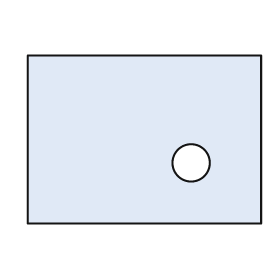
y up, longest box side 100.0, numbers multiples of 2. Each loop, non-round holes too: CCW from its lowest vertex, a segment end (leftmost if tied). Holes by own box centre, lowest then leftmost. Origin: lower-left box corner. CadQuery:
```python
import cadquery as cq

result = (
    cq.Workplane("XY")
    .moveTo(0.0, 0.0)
    .lineTo(100.0, 0.0)
    .lineTo(100.0, 72.0)
    .lineTo(0.0, 72.0)
    .close()
    .moveTo(70.0, 26.0)
    .circle(8.0)
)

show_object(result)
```